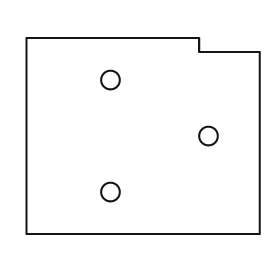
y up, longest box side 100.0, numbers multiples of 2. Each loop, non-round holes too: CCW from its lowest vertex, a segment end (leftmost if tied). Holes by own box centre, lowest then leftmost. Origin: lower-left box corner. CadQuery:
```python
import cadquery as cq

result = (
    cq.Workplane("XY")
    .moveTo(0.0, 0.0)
    .lineTo(100.0, 0.0)
    .lineTo(100.0, 78.0)
    .lineTo(74.0, 78.0)
    .lineTo(74.0, 84.0)
    .lineTo(0.0, 84.0)
    .close()
    .moveTo(36.0, 18.0)
    .circle(4.0)
    .moveTo(78.0, 42.0)
    .circle(4.0)
    .moveTo(36.0, 66.0)
    .circle(4.0)
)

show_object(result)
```